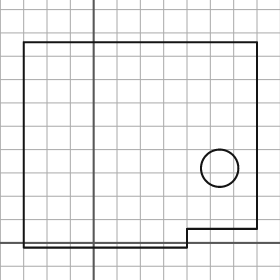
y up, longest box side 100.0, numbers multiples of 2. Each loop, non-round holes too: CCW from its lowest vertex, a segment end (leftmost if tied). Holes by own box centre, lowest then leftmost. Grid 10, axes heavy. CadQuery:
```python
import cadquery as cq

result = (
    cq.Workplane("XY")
    .moveTo(-30.0, -2.0)
    .lineTo(40.0, -2.0)
    .lineTo(40.0, 6.0)
    .lineTo(70.0, 6.0)
    .lineTo(70.0, 86.0)
    .lineTo(-30.0, 86.0)
    .close()
    .moveTo(54.0, 32.0)
    .circle(8.0)
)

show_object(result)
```